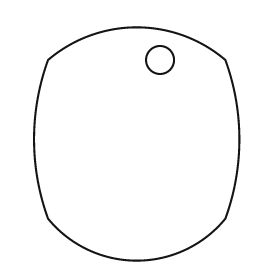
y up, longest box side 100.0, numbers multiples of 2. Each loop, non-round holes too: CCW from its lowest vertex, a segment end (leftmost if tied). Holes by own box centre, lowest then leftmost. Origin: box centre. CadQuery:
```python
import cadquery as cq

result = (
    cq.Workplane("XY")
    .moveTo(-38.0, -32.0)
    .threePointArc((0.0, -50.0), (38.0, -32.0))
    .threePointArc((44.0, 2.0), (38.0, 36.0))
    .threePointArc((0.0, 50.0), (-38.0, 36.0))
    .threePointArc((-44.0, 2.0), (-38.0, -32.0))
    .close()
    .moveTo(10.0, 36.0)
    .circle(6.0)
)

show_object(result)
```